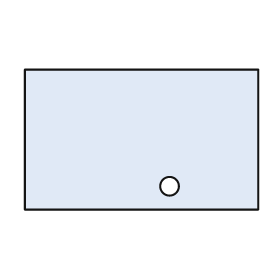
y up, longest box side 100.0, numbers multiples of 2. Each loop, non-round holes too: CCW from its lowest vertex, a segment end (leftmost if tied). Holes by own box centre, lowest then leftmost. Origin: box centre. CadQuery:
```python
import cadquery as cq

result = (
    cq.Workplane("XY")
    .moveTo(-50.0, -30.0)
    .lineTo(50.0, -30.0)
    .lineTo(50.0, 30.0)
    .lineTo(-50.0, 30.0)
    .close()
    .moveTo(12.0, -20.0)
    .circle(4.0)
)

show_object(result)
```